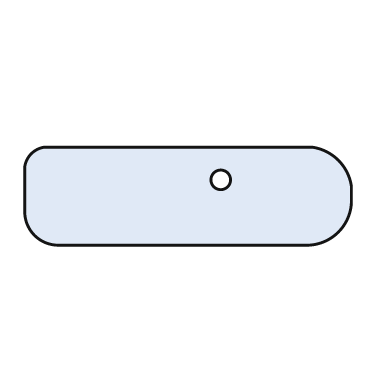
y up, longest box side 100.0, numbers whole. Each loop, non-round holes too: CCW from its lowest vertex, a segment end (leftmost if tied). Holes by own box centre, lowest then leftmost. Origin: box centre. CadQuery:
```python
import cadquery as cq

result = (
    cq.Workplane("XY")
    .moveTo(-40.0, -15.0)
    .lineTo(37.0, -15.0)
    .threePointArc((46.0, -11.0), (50.0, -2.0))
    .lineTo(50.0, 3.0)
    .threePointArc((46.0, 11.0), (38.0, 15.0))
    .lineTo(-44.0, 15.0)
    .threePointArc((-48.0, 13.0), (-50.0, 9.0))
    .lineTo(-50.0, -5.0)
    .threePointArc((-47.0, -12.0), (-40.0, -15.0))
    .close()
    .moveTo(10.0, 5.0)
    .circle(3.0)
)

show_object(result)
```